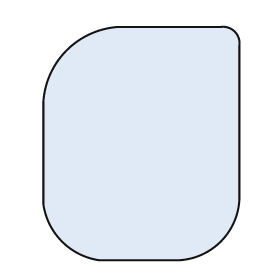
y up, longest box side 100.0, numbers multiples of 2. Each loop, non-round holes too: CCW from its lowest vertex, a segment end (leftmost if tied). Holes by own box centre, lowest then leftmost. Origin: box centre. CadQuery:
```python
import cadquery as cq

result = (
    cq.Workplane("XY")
    .moveTo(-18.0, -50.0)
    .lineTo(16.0, -50.0)
    .threePointArc((34.0, -42.0), (42.0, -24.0))
    .lineTo(42.0, 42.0)
    .threePointArc((40.0, 48.0), (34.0, 50.0))
    .lineTo(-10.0, 50.0)
    .threePointArc((-32.0, 40.0), (-42.0, 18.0))
    .lineTo(-42.0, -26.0)
    .threePointArc((-34.0, -42.0), (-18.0, -50.0))
    .close()
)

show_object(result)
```